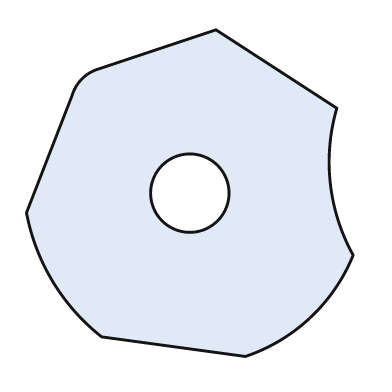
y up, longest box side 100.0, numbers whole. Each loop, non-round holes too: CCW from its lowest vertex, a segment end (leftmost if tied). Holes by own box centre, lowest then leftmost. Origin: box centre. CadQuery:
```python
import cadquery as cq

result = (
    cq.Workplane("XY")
    .moveTo(17.0, -50.0)
    .threePointArc((37.0, -38.0), (50.0, -19.0))
    .threePointArc((43.0, 3.0), (45.0, 26.0))
    .lineTo(8.0, 50.0)
    .lineTo(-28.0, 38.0)
    .threePointArc((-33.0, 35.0), (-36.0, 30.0))
    .lineTo(-50.0, -6.0)
    .threePointArc((-42.0, -27.0), (-27.0, -44.0))
    .close()
    .moveTo(0.0, 0.0)
    .circle(12.0)
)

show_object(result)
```